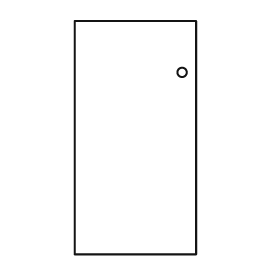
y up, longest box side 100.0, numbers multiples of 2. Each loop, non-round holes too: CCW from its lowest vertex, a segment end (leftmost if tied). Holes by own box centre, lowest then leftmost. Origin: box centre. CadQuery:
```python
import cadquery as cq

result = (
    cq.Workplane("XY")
    .moveTo(-26.0, -50.0)
    .lineTo(26.0, -50.0)
    .lineTo(26.0, 50.0)
    .lineTo(-26.0, 50.0)
    .close()
    .moveTo(20.0, 28.0)
    .circle(2.0)
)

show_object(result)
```